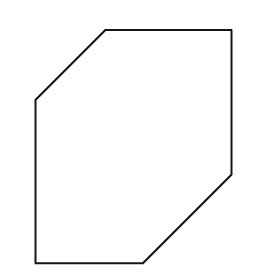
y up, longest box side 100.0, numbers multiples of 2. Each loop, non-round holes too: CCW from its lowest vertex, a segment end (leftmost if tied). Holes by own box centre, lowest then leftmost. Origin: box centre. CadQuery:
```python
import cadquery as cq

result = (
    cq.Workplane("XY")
    .moveTo(-42.0, -50.0)
    .lineTo(4.0, -50.0)
    .lineTo(42.0, -12.0)
    .lineTo(42.0, 50.0)
    .lineTo(-12.0, 50.0)
    .lineTo(-42.0, 20.0)
    .close()
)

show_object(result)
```